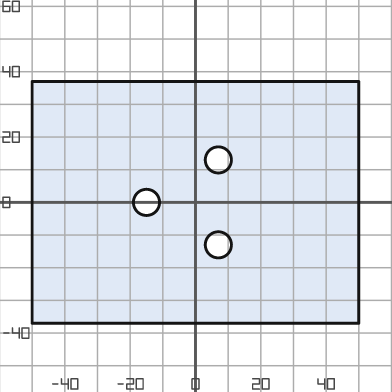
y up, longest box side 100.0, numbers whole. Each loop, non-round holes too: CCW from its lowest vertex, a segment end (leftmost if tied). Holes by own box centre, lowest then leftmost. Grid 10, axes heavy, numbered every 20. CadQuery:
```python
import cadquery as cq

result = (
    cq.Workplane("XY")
    .moveTo(-50.0, -37.0)
    .lineTo(50.0, -37.0)
    .lineTo(50.0, 37.0)
    .lineTo(-50.0, 37.0)
    .close()
    .moveTo(7.0, -13.0)
    .circle(4.0)
    .moveTo(-15.0, 0.0)
    .circle(4.0)
    .moveTo(7.0, 13.0)
    .circle(4.0)
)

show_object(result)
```